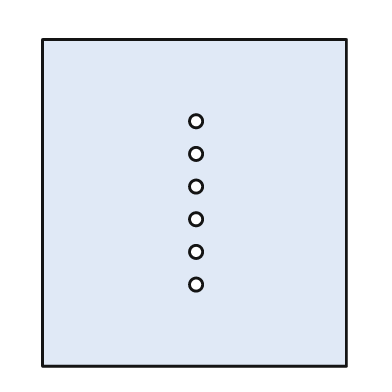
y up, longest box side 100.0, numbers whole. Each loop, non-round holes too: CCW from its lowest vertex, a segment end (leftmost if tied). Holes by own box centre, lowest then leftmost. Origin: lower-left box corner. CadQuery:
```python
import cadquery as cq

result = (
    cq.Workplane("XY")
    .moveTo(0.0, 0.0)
    .lineTo(93.0, 0.0)
    .lineTo(93.0, 100.0)
    .lineTo(0.0, 100.0)
    .close()
    .moveTo(47.0, 25.0)
    .circle(2.0)
    .moveTo(47.0, 35.0)
    .circle(2.0)
    .moveTo(47.0, 45.0)
    .circle(2.0)
    .moveTo(47.0, 55.0)
    .circle(2.0)
    .moveTo(47.0, 65.0)
    .circle(2.0)
    .moveTo(47.0, 75.0)
    .circle(2.0)
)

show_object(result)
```